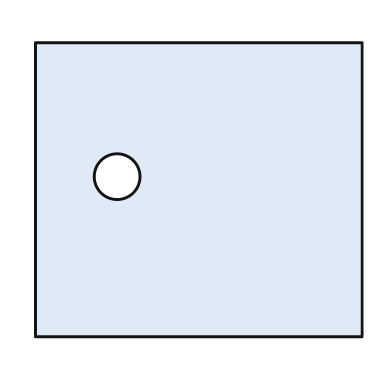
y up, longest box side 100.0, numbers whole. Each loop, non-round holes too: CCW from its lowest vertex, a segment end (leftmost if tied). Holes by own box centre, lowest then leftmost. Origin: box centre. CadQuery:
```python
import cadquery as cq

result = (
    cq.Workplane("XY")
    .moveTo(-50.0, -45.0)
    .lineTo(50.0, -45.0)
    .lineTo(50.0, 45.0)
    .lineTo(-50.0, 45.0)
    .close()
    .moveTo(-25.0, 4.0)
    .circle(7.0)
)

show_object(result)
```